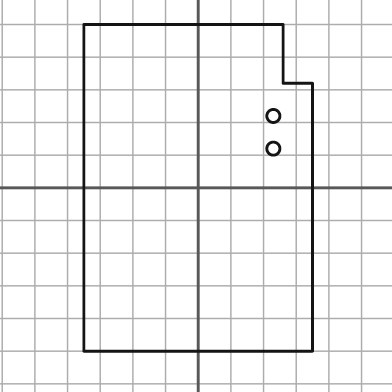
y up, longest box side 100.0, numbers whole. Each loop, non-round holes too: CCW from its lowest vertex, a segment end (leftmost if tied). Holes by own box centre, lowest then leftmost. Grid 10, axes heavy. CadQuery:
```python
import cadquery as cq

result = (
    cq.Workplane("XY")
    .moveTo(-35.0, -50.0)
    .lineTo(35.0, -50.0)
    .lineTo(35.0, 32.0)
    .lineTo(26.0, 32.0)
    .lineTo(26.0, 50.0)
    .lineTo(-35.0, 50.0)
    .close()
    .moveTo(23.0, 12.0)
    .circle(2.0)
    .moveTo(23.0, 22.0)
    .circle(2.0)
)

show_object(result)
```